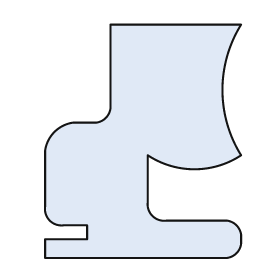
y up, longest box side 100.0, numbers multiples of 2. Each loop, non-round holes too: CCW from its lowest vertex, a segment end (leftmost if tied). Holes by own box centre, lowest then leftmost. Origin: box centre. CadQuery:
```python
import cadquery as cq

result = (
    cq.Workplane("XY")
    .moveTo(-42.0, -50.0)
    .lineTo(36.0, -50.0)
    .threePointArc((40.0, -48.0), (42.0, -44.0))
    .lineTo(42.0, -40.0)
    .threePointArc((40.0, -36.0), (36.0, -34.0))
    .lineTo(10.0, -34.0)
    .threePointArc((4.0, -32.0), (2.0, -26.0))
    .lineTo(2.0, -6.0)
    .threePointArc((22.0, -12.0), (42.0, -6.0))
    .threePointArc((34.0, 22.0), (42.0, 50.0))
    .lineTo(-14.0, 50.0)
    .lineTo(-14.0, 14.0)
    .threePointArc((-16.0, 10.0), (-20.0, 8.0))
    .lineTo(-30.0, 8.0)
    .threePointArc((-38.0, 4.0), (-42.0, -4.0))
    .lineTo(-42.0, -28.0)
    .threePointArc((-40.0, -34.0), (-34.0, -36.0))
    .lineTo(-24.0, -36.0)
    .lineTo(-24.0, -42.0)
    .lineTo(-42.0, -42.0)
    .close()
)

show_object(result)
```